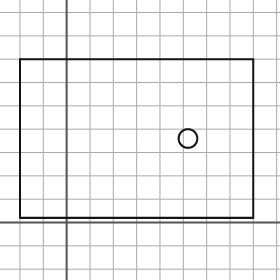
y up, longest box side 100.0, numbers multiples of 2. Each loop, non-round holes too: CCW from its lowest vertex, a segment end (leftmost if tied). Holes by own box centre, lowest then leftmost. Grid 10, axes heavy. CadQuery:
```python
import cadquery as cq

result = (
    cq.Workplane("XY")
    .moveTo(-20.0, 2.0)
    .lineTo(80.0, 2.0)
    .lineTo(80.0, 70.0)
    .lineTo(-20.0, 70.0)
    .close()
    .moveTo(52.0, 36.0)
    .circle(4.0)
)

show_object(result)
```